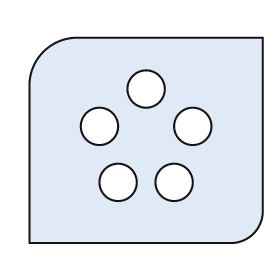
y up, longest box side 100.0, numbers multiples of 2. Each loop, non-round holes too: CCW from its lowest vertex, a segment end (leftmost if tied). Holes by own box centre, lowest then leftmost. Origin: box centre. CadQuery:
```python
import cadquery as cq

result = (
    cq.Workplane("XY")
    .moveTo(-50.0, -44.0)
    .lineTo(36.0, -44.0)
    .threePointArc((46.0, -40.0), (50.0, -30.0))
    .lineTo(50.0, 44.0)
    .lineTo(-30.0, 44.0)
    .threePointArc((-44.0, 38.0), (-50.0, 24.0))
    .close()
    .moveTo(-12.0, -18.0)
    .circle(8.0)
    .moveTo(12.0, -18.0)
    .circle(8.0)
    .moveTo(-20.0, 6.0)
    .circle(8.0)
    .moveTo(20.0, 6.0)
    .circle(8.0)
    .moveTo(0.0, 22.0)
    .circle(8.0)
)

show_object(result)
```